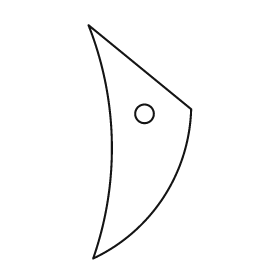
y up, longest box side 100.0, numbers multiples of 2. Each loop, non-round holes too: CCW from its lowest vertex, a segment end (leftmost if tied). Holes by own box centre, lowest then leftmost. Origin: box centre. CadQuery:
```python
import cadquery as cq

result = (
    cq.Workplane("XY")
    .moveTo(-20.0, -50.0)
    .threePointArc((10.0, -24.0), (22.0, 14.0))
    .lineTo(-22.0, 50.0)
    .threePointArc((-12.0, 0.0), (-20.0, -50.0))
    .close()
    .moveTo(2.0, 12.0)
    .circle(4.0)
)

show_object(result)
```